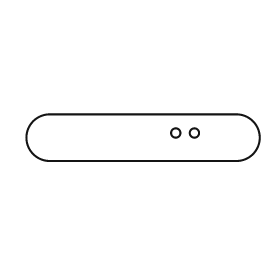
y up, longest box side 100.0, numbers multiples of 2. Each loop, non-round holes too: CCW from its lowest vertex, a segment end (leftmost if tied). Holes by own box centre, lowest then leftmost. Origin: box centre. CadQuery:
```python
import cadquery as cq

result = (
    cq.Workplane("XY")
    .moveTo(-40.0, -10.0)
    .lineTo(40.0, -10.0)
    .threePointArc((50.0, 0.0), (40.0, 10.0))
    .lineTo(-40.0, 10.0)
    .threePointArc((-50.0, 0.0), (-40.0, -10.0))
    .close()
    .moveTo(14.0, 2.0)
    .circle(2.0)
    .moveTo(22.0, 2.0)
    .circle(2.0)
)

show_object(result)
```